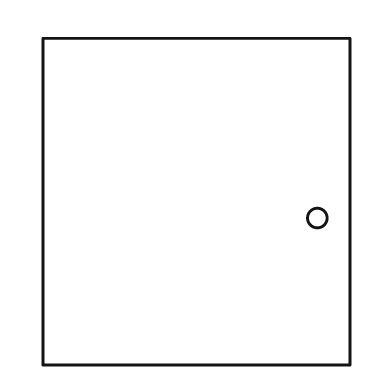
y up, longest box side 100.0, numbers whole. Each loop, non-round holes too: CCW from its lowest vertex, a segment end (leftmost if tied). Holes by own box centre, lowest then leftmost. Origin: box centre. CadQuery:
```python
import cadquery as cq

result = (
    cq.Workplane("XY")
    .moveTo(-47.0, -50.0)
    .lineTo(47.0, -50.0)
    .lineTo(47.0, 50.0)
    .lineTo(-47.0, 50.0)
    .close()
    .moveTo(37.0, -5.0)
    .circle(3.0)
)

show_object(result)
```